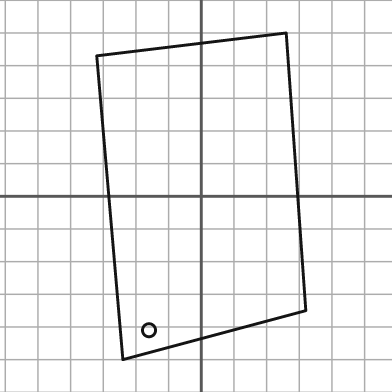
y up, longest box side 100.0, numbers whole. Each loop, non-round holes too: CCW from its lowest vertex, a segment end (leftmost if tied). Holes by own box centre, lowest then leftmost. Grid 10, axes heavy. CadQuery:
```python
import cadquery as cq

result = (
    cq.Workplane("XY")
    .moveTo(-24.0, -50.0)
    .lineTo(32.0, -35.0)
    .lineTo(26.0, 50.0)
    .lineTo(-32.0, 43.0)
    .close()
    .moveTo(-16.0, -41.0)
    .circle(2.0)
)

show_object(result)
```